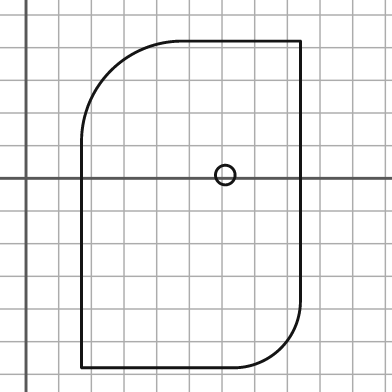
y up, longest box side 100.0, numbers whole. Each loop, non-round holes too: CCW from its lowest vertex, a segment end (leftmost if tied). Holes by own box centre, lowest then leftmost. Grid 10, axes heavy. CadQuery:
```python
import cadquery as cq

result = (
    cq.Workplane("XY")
    .moveTo(17.0, -58.0)
    .lineTo(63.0, -58.0)
    .threePointArc((78.0, -52.0), (84.0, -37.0))
    .lineTo(84.0, 42.0)
    .lineTo(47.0, 42.0)
    .threePointArc((26.0, 33.0), (17.0, 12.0))
    .close()
    .moveTo(61.0, 1.0)
    .circle(3.0)
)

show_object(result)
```